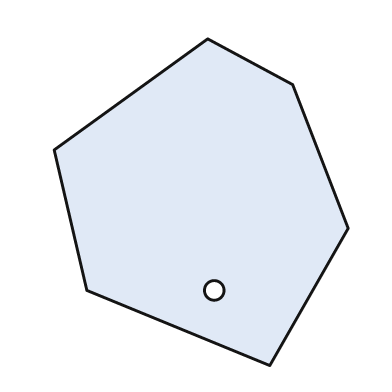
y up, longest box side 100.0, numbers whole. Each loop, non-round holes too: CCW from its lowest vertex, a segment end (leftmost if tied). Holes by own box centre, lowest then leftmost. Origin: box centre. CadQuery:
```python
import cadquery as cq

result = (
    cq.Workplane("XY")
    .moveTo(21.0, -50.0)
    .lineTo(45.0, -8.0)
    .lineTo(28.0, 36.0)
    .lineTo(2.0, 50.0)
    .lineTo(-45.0, 16.0)
    .lineTo(-35.0, -27.0)
    .close()
    .moveTo(4.0, -27.0)
    .circle(3.0)
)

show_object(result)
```